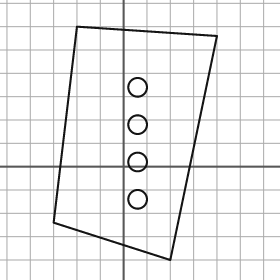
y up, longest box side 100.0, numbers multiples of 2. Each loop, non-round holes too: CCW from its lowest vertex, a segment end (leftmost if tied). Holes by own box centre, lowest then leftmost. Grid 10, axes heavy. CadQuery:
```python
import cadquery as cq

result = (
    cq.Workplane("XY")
    .moveTo(20.0, -40.0)
    .lineTo(40.0, 56.0)
    .lineTo(-20.0, 60.0)
    .lineTo(-30.0, -24.0)
    .close()
    .moveTo(6.0, -14.0)
    .circle(4.0)
    .moveTo(6.0, 2.0)
    .circle(4.0)
    .moveTo(6.0, 18.0)
    .circle(4.0)
    .moveTo(6.0, 34.0)
    .circle(4.0)
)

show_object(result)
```